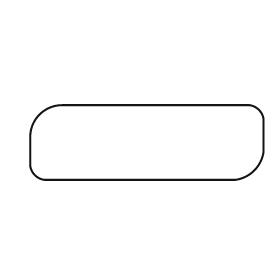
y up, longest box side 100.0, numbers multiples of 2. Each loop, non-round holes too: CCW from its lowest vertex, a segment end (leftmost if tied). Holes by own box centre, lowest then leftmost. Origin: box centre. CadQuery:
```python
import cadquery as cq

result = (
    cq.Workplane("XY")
    .moveTo(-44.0, -16.0)
    .lineTo(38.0, -16.0)
    .threePointArc((46.0, -12.0), (50.0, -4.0))
    .lineTo(50.0, 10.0)
    .threePointArc((48.0, 14.0), (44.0, 16.0))
    .lineTo(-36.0, 16.0)
    .threePointArc((-46.0, 12.0), (-50.0, 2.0))
    .lineTo(-50.0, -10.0)
    .threePointArc((-48.0, -14.0), (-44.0, -16.0))
    .close()
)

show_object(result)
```